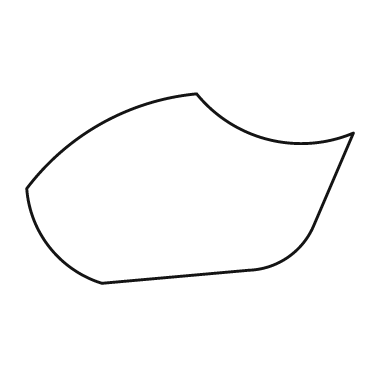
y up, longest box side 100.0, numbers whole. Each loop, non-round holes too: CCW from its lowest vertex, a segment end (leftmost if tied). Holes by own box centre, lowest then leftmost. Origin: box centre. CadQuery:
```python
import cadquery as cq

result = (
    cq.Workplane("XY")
    .moveTo(-27.0, -29.0)
    .lineTo(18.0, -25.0)
    .threePointArc((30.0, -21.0), (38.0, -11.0))
    .lineTo(50.0, 17.0)
    .threePointArc((24.0, 15.0), (2.0, 29.0))
    .threePointArc((-27.0, 20.0), (-50.0, 0.0))
    .threePointArc((-43.0, -18.0), (-27.0, -29.0))
    .close()
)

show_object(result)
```